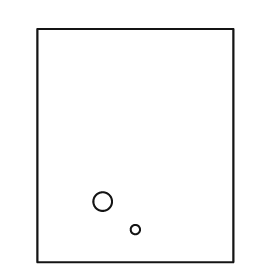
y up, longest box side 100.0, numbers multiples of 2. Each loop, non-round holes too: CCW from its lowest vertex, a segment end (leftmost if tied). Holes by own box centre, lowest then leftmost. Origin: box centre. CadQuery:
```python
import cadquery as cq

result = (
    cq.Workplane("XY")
    .moveTo(-42.0, -50.0)
    .lineTo(42.0, -50.0)
    .lineTo(42.0, 50.0)
    .lineTo(-42.0, 50.0)
    .close()
    .moveTo(0.0, -36.0)
    .circle(2.0)
    .moveTo(-14.0, -24.0)
    .circle(4.0)
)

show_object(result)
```